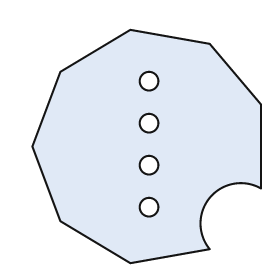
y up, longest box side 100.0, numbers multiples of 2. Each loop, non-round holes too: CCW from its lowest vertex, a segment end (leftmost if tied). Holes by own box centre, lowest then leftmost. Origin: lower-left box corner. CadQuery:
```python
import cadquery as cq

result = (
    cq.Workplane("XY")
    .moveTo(42.0, 0.0)
    .lineTo(76.0, 6.0)
    .threePointArc((76.0, 28.0), (98.0, 32.0))
    .lineTo(98.0, 68.0)
    .lineTo(76.0, 94.0)
    .lineTo(42.0, 100.0)
    .lineTo(12.0, 82.0)
    .lineTo(0.0, 50.0)
    .lineTo(12.0, 18.0)
    .close()
    .moveTo(50.0, 24.0)
    .circle(4.0)
    .moveTo(50.0, 42.0)
    .circle(4.0)
    .moveTo(50.0, 60.0)
    .circle(4.0)
    .moveTo(50.0, 78.0)
    .circle(4.0)
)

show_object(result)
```